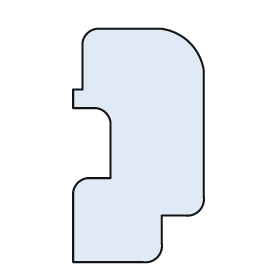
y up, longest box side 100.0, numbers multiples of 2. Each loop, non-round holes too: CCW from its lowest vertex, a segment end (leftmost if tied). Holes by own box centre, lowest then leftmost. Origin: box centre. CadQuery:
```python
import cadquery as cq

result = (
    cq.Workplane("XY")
    .moveTo(-28.0, -50.0)
    .lineTo(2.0, -50.0)
    .threePointArc((8.0, -48.0), (10.0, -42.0))
    .lineTo(10.0, -30.0)
    .lineTo(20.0, -30.0)
    .threePointArc((26.0, -28.0), (28.0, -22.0))
    .lineTo(28.0, 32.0)
    .threePointArc((22.0, 44.0), (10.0, 50.0))
    .lineTo(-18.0, 50.0)
    .threePointArc((-22.0, 48.0), (-24.0, 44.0))
    .lineTo(-24.0, 24.0)
    .lineTo(-28.0, 24.0)
    .lineTo(-28.0, 16.0)
    .lineTo(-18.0, 16.0)
    .threePointArc((-14.0, 14.0), (-12.0, 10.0))
    .lineTo(-12.0, -14.0)
    .lineTo(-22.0, -14.0)
    .threePointArc((-26.0, -16.0), (-28.0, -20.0))
    .close()
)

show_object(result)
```